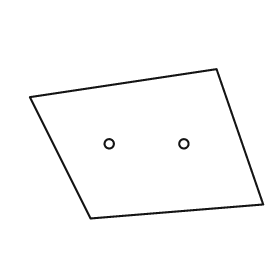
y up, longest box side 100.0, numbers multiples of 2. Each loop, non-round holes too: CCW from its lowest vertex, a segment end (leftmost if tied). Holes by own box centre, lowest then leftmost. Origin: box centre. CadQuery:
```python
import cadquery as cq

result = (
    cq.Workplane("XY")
    .moveTo(-24.0, -32.0)
    .lineTo(50.0, -26.0)
    .lineTo(30.0, 32.0)
    .lineTo(-50.0, 20.0)
    .close()
    .moveTo(-16.0, 0.0)
    .circle(2.0)
    .moveTo(16.0, 0.0)
    .circle(2.0)
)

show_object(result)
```